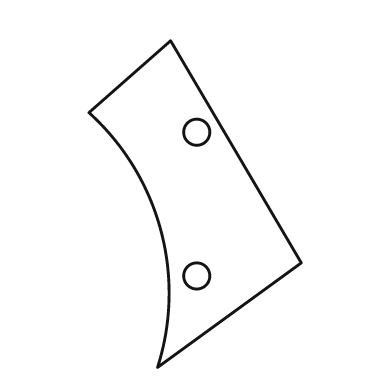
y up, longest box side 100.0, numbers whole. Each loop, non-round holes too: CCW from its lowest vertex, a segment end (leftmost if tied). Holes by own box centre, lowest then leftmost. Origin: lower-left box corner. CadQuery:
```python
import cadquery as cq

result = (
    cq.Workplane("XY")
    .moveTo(21.0, 0.0)
    .lineTo(65.0, 32.0)
    .lineTo(25.0, 100.0)
    .lineTo(0.0, 78.0)
    .threePointArc((22.0, 42.0), (21.0, 0.0))
    .close()
    .moveTo(33.0, 28.0)
    .circle(4.0)
    .moveTo(33.0, 72.0)
    .circle(4.0)
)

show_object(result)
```